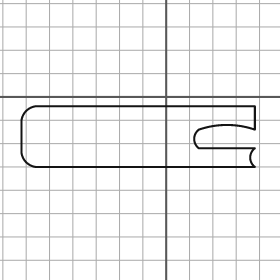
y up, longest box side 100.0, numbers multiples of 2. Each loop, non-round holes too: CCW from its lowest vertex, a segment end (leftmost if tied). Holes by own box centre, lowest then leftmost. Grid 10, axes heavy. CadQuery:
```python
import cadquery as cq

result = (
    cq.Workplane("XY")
    .moveTo(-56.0, -30.0)
    .lineTo(38.0, -30.0)
    .threePointArc((36.0, -26.0), (38.0, -22.0))
    .lineTo(14.0, -22.0)
    .threePointArc((12.0, -18.0), (14.0, -14.0))
    .threePointArc((26.0, -12.0), (38.0, -14.0))
    .lineTo(38.0, -4.0)
    .lineTo(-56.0, -4.0)
    .threePointArc((-60.0, -6.0), (-62.0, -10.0))
    .lineTo(-62.0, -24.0)
    .threePointArc((-60.0, -28.0), (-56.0, -30.0))
    .close()
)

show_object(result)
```